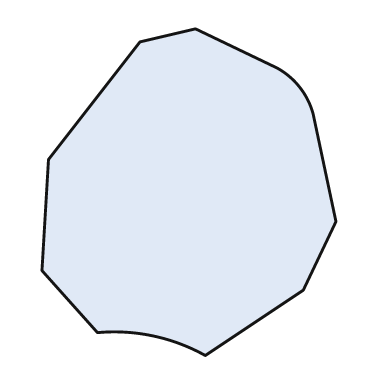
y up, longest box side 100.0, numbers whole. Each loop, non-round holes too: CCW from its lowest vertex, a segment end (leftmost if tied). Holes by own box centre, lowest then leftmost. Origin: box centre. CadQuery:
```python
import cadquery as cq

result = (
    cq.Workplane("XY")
    .moveTo(5.0, -50.0)
    .lineTo(35.0, -30.0)
    .lineTo(45.0, -9.0)
    .lineTo(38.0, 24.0)
    .threePointArc((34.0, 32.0), (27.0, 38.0))
    .lineTo(2.0, 50.0)
    .lineTo(-15.0, 46.0)
    .lineTo(-43.0, 10.0)
    .lineTo(-45.0, -24.0)
    .lineTo(-28.0, -43.0)
    .threePointArc((-11.0, -44.0), (5.0, -50.0))
    .close()
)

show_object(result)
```